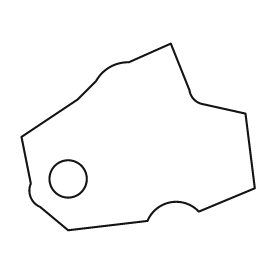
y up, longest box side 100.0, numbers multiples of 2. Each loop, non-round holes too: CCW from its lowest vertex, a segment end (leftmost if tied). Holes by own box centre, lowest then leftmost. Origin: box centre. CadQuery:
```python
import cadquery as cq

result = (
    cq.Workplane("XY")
    .moveTo(-30.0, -40.0)
    .lineTo(4.0, -36.0)
    .threePointArc((14.0, -28.0), (26.0, -32.0))
    .lineTo(50.0, -22.0)
    .lineTo(46.0, 10.0)
    .lineTo(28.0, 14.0)
    .threePointArc((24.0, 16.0), (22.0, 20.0))
    .lineTo(14.0, 40.0)
    .lineTo(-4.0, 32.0)
    .threePointArc((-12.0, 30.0), (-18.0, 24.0))
    .lineTo(-26.0, 16.0)
    .lineTo(-50.0, 0.0)
    .lineTo(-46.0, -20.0)
    .threePointArc((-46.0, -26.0), (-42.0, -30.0))
    .close()
    .moveTo(-30.0, -18.0)
    .circle(8.0)
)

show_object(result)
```